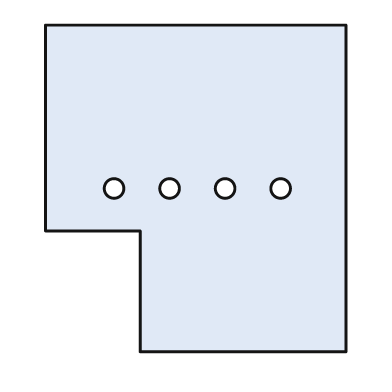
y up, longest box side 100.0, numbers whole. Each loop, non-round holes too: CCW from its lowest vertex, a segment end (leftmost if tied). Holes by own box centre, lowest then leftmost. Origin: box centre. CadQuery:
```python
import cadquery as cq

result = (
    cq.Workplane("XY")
    .moveTo(-17.0, -50.0)
    .lineTo(46.0, -50.0)
    .lineTo(46.0, 50.0)
    .lineTo(-46.0, 50.0)
    .lineTo(-46.0, -13.0)
    .lineTo(-17.0, -13.0)
    .close()
    .moveTo(-25.0, 0.0)
    .circle(3.0)
    .moveTo(-8.0, 0.0)
    .circle(3.0)
    .moveTo(9.0, 0.0)
    .circle(3.0)
    .moveTo(26.0, 0.0)
    .circle(3.0)
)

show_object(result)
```